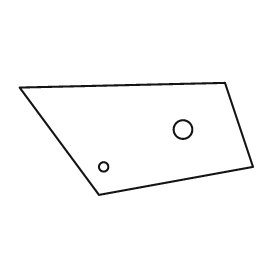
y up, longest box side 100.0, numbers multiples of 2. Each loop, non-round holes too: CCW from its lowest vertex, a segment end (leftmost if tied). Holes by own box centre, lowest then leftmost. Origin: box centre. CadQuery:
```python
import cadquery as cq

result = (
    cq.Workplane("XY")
    .moveTo(-16.0, -24.0)
    .lineTo(50.0, -12.0)
    .lineTo(38.0, 24.0)
    .lineTo(-50.0, 22.0)
    .close()
    .moveTo(-14.0, -12.0)
    .circle(2.0)
    .moveTo(20.0, 4.0)
    .circle(4.0)
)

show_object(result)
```